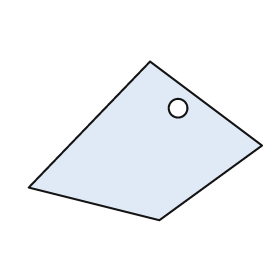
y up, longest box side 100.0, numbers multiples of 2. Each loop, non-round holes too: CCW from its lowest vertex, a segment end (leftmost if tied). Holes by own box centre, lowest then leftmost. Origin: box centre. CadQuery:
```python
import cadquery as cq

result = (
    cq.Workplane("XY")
    .moveTo(6.0, -34.0)
    .lineTo(50.0, -2.0)
    .lineTo(2.0, 34.0)
    .lineTo(-50.0, -20.0)
    .close()
    .moveTo(14.0, 14.0)
    .circle(4.0)
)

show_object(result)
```